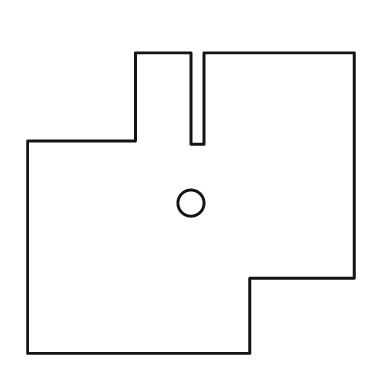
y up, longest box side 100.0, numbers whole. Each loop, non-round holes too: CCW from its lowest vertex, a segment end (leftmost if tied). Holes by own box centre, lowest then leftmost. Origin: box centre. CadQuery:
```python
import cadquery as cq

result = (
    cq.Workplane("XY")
    .moveTo(-50.0, -46.0)
    .lineTo(18.0, -46.0)
    .lineTo(18.0, -23.0)
    .lineTo(50.0, -23.0)
    .lineTo(50.0, 46.0)
    .lineTo(4.0, 46.0)
    .lineTo(4.0, 18.0)
    .lineTo(0.0, 18.0)
    .lineTo(0.0, 46.0)
    .lineTo(-17.0, 46.0)
    .lineTo(-17.0, 19.0)
    .lineTo(-50.0, 19.0)
    .close()
    .moveTo(0.0, 0.0)
    .circle(4.0)
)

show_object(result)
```